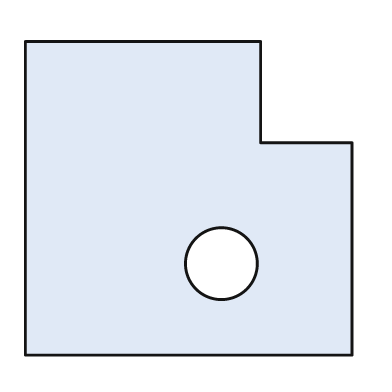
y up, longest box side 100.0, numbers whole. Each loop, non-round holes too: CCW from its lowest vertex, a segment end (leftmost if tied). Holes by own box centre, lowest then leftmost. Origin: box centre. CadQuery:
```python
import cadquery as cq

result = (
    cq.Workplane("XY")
    .moveTo(-50.0, -48.0)
    .lineTo(50.0, -48.0)
    .lineTo(50.0, 17.0)
    .lineTo(22.0, 17.0)
    .lineTo(22.0, 48.0)
    .lineTo(-50.0, 48.0)
    .close()
    .moveTo(10.0, -20.0)
    .circle(11.0)
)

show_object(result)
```